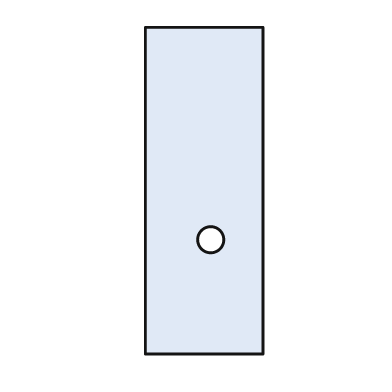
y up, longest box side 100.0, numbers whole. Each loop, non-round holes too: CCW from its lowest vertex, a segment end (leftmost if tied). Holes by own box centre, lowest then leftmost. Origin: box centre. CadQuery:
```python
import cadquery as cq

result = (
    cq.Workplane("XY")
    .moveTo(-18.0, -50.0)
    .lineTo(18.0, -50.0)
    .lineTo(18.0, 50.0)
    .lineTo(-18.0, 50.0)
    .close()
    .moveTo(2.0, -15.0)
    .circle(4.0)
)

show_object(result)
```